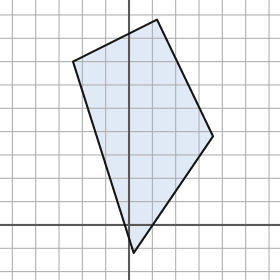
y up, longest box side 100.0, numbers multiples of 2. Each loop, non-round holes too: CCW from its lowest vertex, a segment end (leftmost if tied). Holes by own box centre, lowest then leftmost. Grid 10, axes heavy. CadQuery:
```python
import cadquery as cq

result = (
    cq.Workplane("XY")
    .moveTo(2.0, -12.0)
    .lineTo(36.0, 38.0)
    .lineTo(12.0, 88.0)
    .lineTo(-24.0, 70.0)
    .close()
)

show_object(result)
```